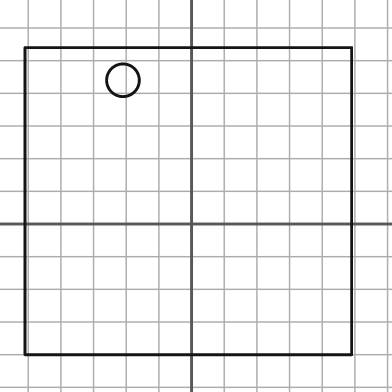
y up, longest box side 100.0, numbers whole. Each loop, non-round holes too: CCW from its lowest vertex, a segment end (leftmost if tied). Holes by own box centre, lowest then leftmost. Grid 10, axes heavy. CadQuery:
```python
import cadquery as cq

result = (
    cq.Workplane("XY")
    .moveTo(-51.0, -40.0)
    .lineTo(49.0, -40.0)
    .lineTo(49.0, 54.0)
    .lineTo(-51.0, 54.0)
    .close()
    .moveTo(-21.0, 44.0)
    .circle(5.0)
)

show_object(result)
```